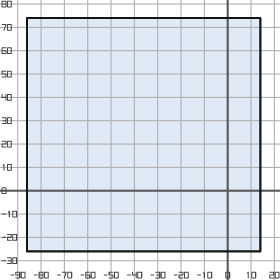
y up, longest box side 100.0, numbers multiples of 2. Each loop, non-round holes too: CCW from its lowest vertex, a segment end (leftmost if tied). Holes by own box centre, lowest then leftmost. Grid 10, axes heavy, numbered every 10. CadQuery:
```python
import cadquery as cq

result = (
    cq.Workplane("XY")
    .moveTo(-86.0, -26.0)
    .lineTo(14.0, -26.0)
    .lineTo(14.0, 74.0)
    .lineTo(-86.0, 74.0)
    .close()
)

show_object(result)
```